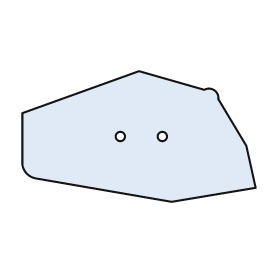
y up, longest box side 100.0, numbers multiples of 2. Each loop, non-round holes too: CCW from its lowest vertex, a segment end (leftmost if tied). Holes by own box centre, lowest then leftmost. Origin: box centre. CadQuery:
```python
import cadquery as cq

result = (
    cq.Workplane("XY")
    .moveTo(14.0, -28.0)
    .lineTo(50.0, -22.0)
    .lineTo(46.0, -4.0)
    .lineTo(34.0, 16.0)
    .threePointArc((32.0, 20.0), (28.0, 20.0))
    .lineTo(0.0, 28.0)
    .lineTo(-50.0, 10.0)
    .lineTo(-50.0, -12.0)
    .threePointArc((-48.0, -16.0), (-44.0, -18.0))
    .close()
    .moveTo(-8.0, 0.0)
    .circle(2.0)
    .moveTo(10.0, 0.0)
    .circle(2.0)
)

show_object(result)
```